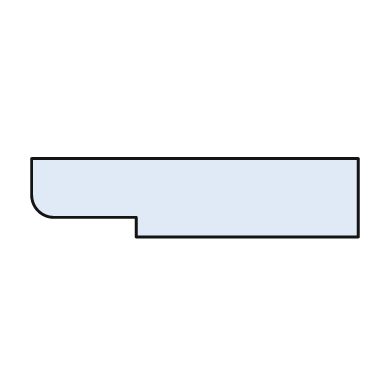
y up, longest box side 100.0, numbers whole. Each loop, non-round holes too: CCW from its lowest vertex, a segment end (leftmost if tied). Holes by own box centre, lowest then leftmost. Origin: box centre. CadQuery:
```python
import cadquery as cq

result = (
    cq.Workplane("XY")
    .moveTo(-18.0, -12.0)
    .lineTo(50.0, -12.0)
    .lineTo(50.0, 12.0)
    .lineTo(-50.0, 12.0)
    .lineTo(-50.0, 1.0)
    .threePointArc((-48.0, -4.0), (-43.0, -6.0))
    .lineTo(-18.0, -6.0)
    .close()
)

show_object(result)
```